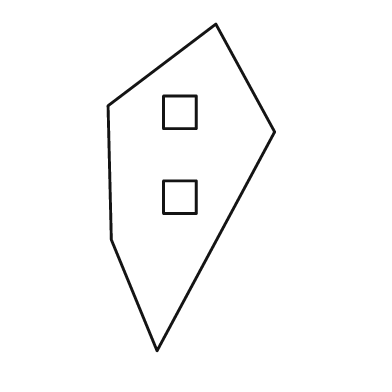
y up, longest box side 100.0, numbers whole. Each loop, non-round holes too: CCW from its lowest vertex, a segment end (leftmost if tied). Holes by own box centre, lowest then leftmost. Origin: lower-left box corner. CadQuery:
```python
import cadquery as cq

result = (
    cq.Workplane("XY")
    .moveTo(15.0, 0.0)
    .lineTo(51.0, 67.0)
    .lineTo(33.0, 100.0)
    .lineTo(0.0, 75.0)
    .lineTo(1.0, 34.0)
    .close()
    .moveTo(17.0, 42.0)
    .lineTo(27.0, 42.0)
    .lineTo(27.0, 52.0)
    .lineTo(17.0, 52.0)
    .close()
    .moveTo(17.0, 68.0)
    .lineTo(27.0, 68.0)
    .lineTo(27.0, 78.0)
    .lineTo(17.0, 78.0)
    .close()
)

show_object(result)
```